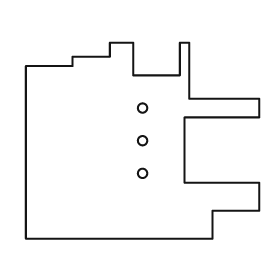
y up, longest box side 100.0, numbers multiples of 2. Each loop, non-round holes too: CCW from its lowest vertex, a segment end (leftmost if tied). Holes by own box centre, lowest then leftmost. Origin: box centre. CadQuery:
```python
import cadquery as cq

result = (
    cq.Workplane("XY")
    .moveTo(-50.0, -42.0)
    .lineTo(30.0, -42.0)
    .lineTo(30.0, -30.0)
    .lineTo(50.0, -30.0)
    .lineTo(50.0, -18.0)
    .lineTo(18.0, -18.0)
    .lineTo(18.0, 10.0)
    .lineTo(50.0, 10.0)
    .lineTo(50.0, 18.0)
    .lineTo(20.0, 18.0)
    .lineTo(20.0, 42.0)
    .lineTo(16.0, 42.0)
    .lineTo(16.0, 28.0)
    .lineTo(-4.0, 28.0)
    .lineTo(-4.0, 42.0)
    .lineTo(-14.0, 42.0)
    .lineTo(-14.0, 36.0)
    .lineTo(-30.0, 36.0)
    .lineTo(-30.0, 32.0)
    .lineTo(-50.0, 32.0)
    .close()
    .moveTo(0.0, -14.0)
    .circle(2.0)
    .moveTo(0.0, 0.0)
    .circle(2.0)
    .moveTo(0.0, 14.0)
    .circle(2.0)
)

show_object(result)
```